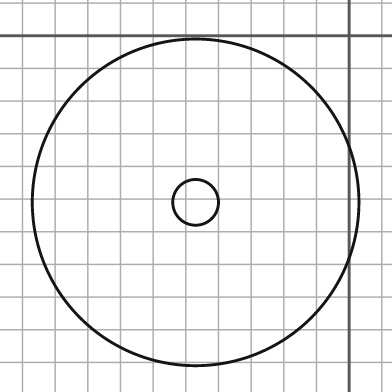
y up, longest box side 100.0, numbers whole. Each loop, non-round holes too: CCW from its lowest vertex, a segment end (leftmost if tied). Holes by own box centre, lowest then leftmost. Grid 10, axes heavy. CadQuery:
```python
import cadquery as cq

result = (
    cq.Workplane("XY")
    .moveTo(-47.0, -51.0)
    .circle(50.0)
    .moveTo(-47.0, -51.0)
    .circle(7.0)
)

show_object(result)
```